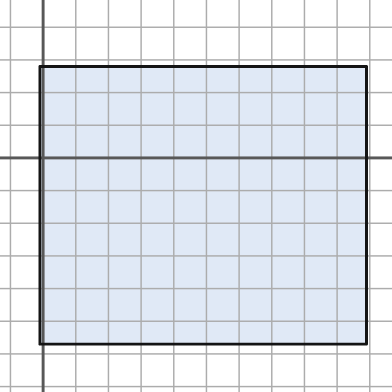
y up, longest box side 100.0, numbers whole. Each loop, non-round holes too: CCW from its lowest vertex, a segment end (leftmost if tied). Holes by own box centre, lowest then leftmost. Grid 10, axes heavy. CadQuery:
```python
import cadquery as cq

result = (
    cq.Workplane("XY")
    .moveTo(-1.0, -57.0)
    .lineTo(99.0, -57.0)
    .lineTo(99.0, 28.0)
    .lineTo(-1.0, 28.0)
    .close()
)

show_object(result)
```